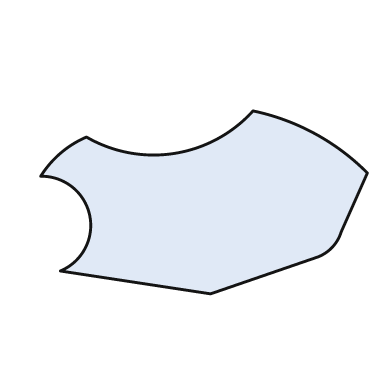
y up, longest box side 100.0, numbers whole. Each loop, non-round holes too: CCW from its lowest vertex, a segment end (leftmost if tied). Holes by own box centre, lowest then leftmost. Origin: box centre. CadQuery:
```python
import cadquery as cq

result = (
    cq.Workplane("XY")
    .moveTo(2.0, -28.0)
    .lineTo(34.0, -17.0)
    .threePointArc((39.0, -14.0), (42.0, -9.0))
    .lineTo(50.0, 9.0)
    .threePointArc((34.0, 21.0), (15.0, 28.0))
    .threePointArc((-9.0, 15.0), (-36.0, 20.0))
    .threePointArc((-44.0, 15.0), (-50.0, 8.0))
    .threePointArc((-35.0, -4.0), (-44.0, -21.0))
    .close()
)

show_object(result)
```